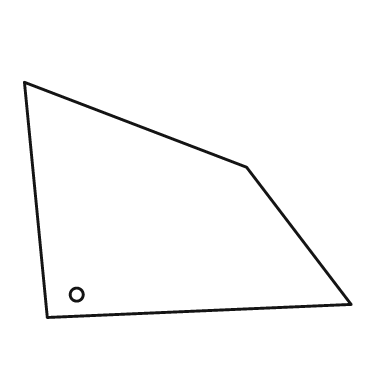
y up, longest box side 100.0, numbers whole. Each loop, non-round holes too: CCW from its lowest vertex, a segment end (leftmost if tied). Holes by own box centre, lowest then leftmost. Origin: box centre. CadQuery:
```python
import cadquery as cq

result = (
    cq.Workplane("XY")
    .moveTo(-43.0, -36.0)
    .lineTo(50.0, -32.0)
    .lineTo(18.0, 10.0)
    .lineTo(-50.0, 36.0)
    .close()
    .moveTo(-34.0, -29.0)
    .circle(2.0)
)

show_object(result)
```